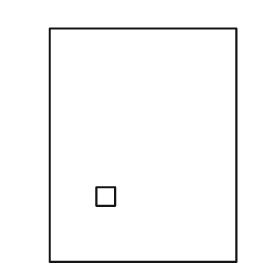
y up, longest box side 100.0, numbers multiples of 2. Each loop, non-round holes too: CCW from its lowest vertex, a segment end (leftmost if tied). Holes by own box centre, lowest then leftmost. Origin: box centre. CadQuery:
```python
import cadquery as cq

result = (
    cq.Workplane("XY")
    .moveTo(-40.0, -50.0)
    .lineTo(40.0, -50.0)
    .lineTo(40.0, 50.0)
    .lineTo(-40.0, 50.0)
    .close()
    .moveTo(-20.0, -26.0)
    .lineTo(-12.0, -26.0)
    .lineTo(-12.0, -18.0)
    .lineTo(-20.0, -18.0)
    .close()
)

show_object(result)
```